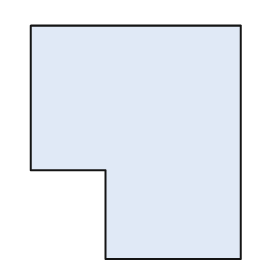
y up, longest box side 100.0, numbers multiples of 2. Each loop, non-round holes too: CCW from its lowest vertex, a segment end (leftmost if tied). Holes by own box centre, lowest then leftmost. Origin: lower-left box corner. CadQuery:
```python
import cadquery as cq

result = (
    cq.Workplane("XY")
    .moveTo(32.0, 0.0)
    .lineTo(90.0, 0.0)
    .lineTo(90.0, 100.0)
    .lineTo(0.0, 100.0)
    .lineTo(0.0, 38.0)
    .lineTo(32.0, 38.0)
    .close()
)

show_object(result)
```